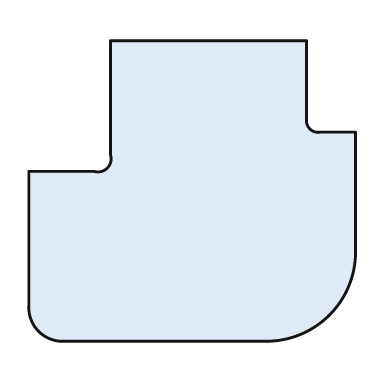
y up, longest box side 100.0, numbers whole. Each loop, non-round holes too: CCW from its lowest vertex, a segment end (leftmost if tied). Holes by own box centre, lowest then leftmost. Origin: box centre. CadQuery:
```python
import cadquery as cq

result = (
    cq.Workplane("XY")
    .moveTo(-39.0, -46.0)
    .lineTo(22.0, -46.0)
    .threePointArc((42.0, -38.0), (50.0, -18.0))
    .lineTo(50.0, 18.0)
    .lineTo(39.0, 18.0)
    .threePointArc((36.0, 19.0), (35.0, 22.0))
    .lineTo(35.0, 46.0)
    .lineTo(-25.0, 46.0)
    .lineTo(-25.0, 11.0)
    .threePointArc((-26.0, 7.0), (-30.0, 6.0))
    .lineTo(-50.0, 6.0)
    .lineTo(-50.0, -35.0)
    .threePointArc((-47.0, -43.0), (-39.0, -46.0))
    .close()
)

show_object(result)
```